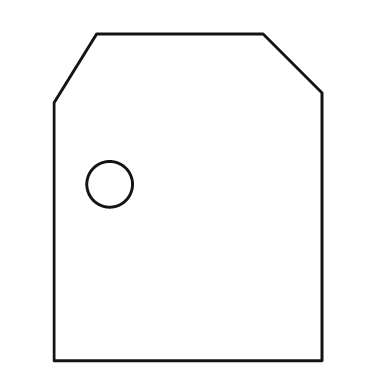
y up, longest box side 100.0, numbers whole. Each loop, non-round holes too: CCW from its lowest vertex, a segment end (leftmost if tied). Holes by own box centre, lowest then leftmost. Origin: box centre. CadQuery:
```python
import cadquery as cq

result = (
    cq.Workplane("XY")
    .moveTo(-41.0, -50.0)
    .lineTo(41.0, -50.0)
    .lineTo(41.0, 32.0)
    .lineTo(23.0, 50.0)
    .lineTo(-28.0, 50.0)
    .lineTo(-41.0, 29.0)
    .close()
    .moveTo(-24.0, 4.0)
    .circle(7.0)
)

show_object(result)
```